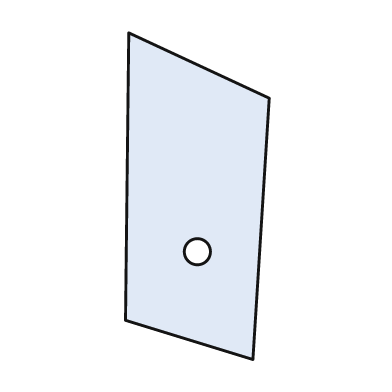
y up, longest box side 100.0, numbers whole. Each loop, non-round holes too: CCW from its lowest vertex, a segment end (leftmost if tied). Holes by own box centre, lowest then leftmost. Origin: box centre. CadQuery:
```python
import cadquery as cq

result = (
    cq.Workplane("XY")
    .moveTo(17.0, -50.0)
    .lineTo(22.0, 30.0)
    .lineTo(-21.0, 50.0)
    .lineTo(-22.0, -38.0)
    .close()
    .moveTo(0.0, -17.0)
    .circle(4.0)
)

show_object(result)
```